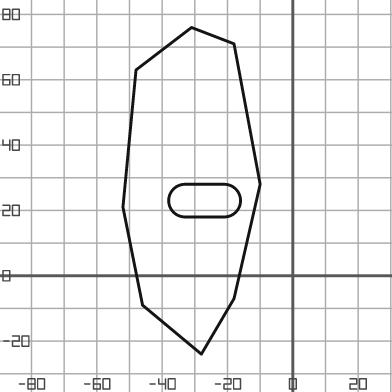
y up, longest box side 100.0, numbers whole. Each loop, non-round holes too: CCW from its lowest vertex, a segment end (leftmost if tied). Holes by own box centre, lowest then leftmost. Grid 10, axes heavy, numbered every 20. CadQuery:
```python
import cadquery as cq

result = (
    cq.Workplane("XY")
    .moveTo(-28.0, -24.0)
    .lineTo(-18.0, -7.0)
    .lineTo(-10.0, 28.0)
    .lineTo(-18.0, 71.0)
    .lineTo(-31.0, 76.0)
    .lineTo(-48.0, 63.0)
    .lineTo(-52.0, 21.0)
    .lineTo(-46.0, -9.0)
    .close()
    .moveTo(-33.0, 18.0)
    .lineTo(-21.0, 18.0)
    .threePointArc((-16.0, 23.0), (-21.0, 28.0))
    .lineTo(-33.0, 28.0)
    .threePointArc((-38.0, 23.0), (-33.0, 18.0))
    .close()
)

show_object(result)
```